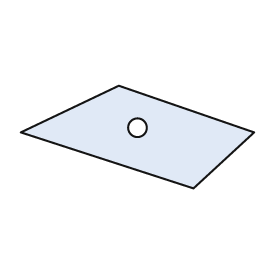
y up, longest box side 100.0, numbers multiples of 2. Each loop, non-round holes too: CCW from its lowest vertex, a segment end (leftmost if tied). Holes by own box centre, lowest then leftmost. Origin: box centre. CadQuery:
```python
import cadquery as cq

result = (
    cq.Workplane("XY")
    .moveTo(24.0, -22.0)
    .lineTo(50.0, 2.0)
    .lineTo(-8.0, 22.0)
    .lineTo(-50.0, 2.0)
    .close()
    .moveTo(0.0, 4.0)
    .circle(4.0)
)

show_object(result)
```